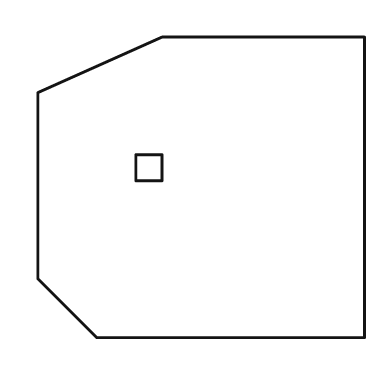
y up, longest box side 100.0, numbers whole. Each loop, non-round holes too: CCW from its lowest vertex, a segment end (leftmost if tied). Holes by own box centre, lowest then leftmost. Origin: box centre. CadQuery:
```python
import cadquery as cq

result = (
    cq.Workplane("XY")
    .moveTo(-32.0, -46.0)
    .lineTo(50.0, -46.0)
    .lineTo(50.0, 46.0)
    .lineTo(-12.0, 46.0)
    .lineTo(-50.0, 29.0)
    .lineTo(-50.0, -28.0)
    .close()
    .moveTo(-20.0, 2.0)
    .lineTo(-12.0, 2.0)
    .lineTo(-12.0, 10.0)
    .lineTo(-20.0, 10.0)
    .close()
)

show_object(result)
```